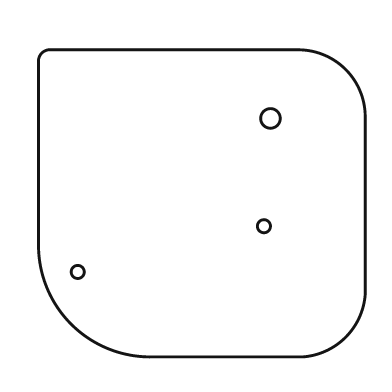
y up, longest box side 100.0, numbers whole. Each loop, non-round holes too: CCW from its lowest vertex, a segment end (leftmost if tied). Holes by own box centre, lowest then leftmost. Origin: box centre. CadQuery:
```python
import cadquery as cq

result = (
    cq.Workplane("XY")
    .moveTo(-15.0, -47.0)
    .lineTo(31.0, -47.0)
    .threePointArc((44.0, -41.0), (50.0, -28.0))
    .lineTo(50.0, 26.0)
    .threePointArc((44.0, 41.0), (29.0, 47.0))
    .lineTo(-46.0, 47.0)
    .threePointArc((-49.0, 46.0), (-50.0, 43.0))
    .lineTo(-50.0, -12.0)
    .threePointArc((-40.0, -37.0), (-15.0, -47.0))
    .close()
    .moveTo(-38.0, -21.0)
    .circle(2.0)
    .moveTo(19.0, -7.0)
    .circle(2.0)
    .moveTo(21.0, 26.0)
    .circle(3.0)
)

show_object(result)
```